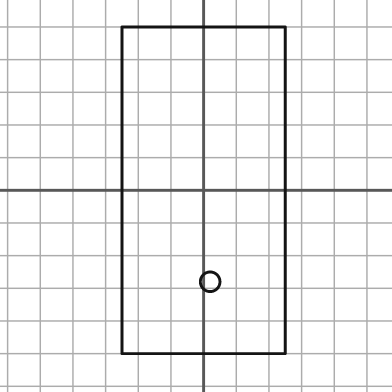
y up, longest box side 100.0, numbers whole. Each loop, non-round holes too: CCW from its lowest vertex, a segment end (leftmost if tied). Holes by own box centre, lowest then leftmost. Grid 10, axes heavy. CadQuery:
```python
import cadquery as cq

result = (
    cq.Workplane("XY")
    .moveTo(-25.0, -50.0)
    .lineTo(25.0, -50.0)
    .lineTo(25.0, 50.0)
    .lineTo(-25.0, 50.0)
    .close()
    .moveTo(2.0, -28.0)
    .circle(3.0)
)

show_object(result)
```